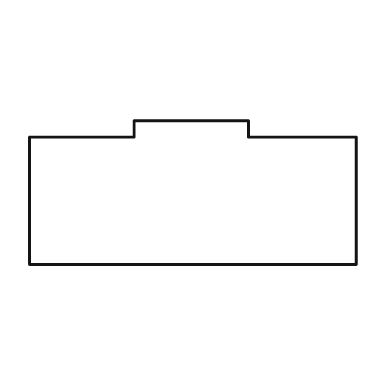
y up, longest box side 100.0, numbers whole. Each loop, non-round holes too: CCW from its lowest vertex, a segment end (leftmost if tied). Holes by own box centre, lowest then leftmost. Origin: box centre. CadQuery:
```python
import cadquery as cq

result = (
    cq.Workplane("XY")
    .moveTo(-50.0, -22.0)
    .lineTo(50.0, -22.0)
    .lineTo(50.0, 17.0)
    .lineTo(17.0, 17.0)
    .lineTo(17.0, 22.0)
    .lineTo(-18.0, 22.0)
    .lineTo(-18.0, 17.0)
    .lineTo(-50.0, 17.0)
    .close()
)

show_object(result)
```